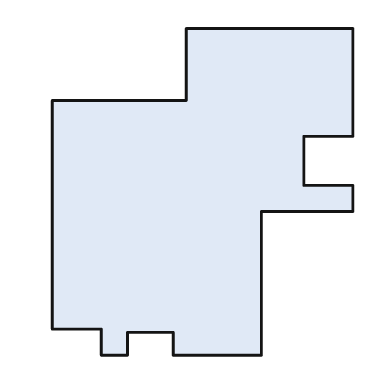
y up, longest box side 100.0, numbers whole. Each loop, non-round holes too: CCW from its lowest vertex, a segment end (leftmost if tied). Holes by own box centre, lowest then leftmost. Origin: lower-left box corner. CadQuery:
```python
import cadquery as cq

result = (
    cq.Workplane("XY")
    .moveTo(15.0, 0.0)
    .lineTo(23.0, 0.0)
    .lineTo(23.0, 7.0)
    .lineTo(37.0, 7.0)
    .lineTo(37.0, 0.0)
    .lineTo(64.0, 0.0)
    .lineTo(64.0, 44.0)
    .lineTo(92.0, 44.0)
    .lineTo(92.0, 52.0)
    .lineTo(77.0, 52.0)
    .lineTo(77.0, 67.0)
    .lineTo(92.0, 67.0)
    .lineTo(92.0, 100.0)
    .lineTo(41.0, 100.0)
    .lineTo(41.0, 78.0)
    .lineTo(0.0, 78.0)
    .lineTo(0.0, 8.0)
    .lineTo(15.0, 8.0)
    .close()
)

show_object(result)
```